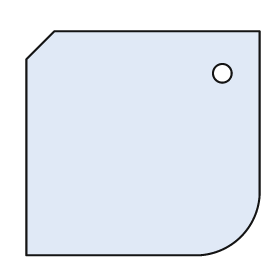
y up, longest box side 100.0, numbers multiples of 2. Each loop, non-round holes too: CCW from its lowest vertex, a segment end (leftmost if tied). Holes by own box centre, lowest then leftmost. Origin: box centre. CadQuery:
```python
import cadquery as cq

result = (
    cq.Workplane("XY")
    .moveTo(-50.0, -48.0)
    .lineTo(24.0, -48.0)
    .threePointArc((42.0, -40.0), (50.0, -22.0))
    .lineTo(50.0, 48.0)
    .lineTo(-38.0, 48.0)
    .lineTo(-50.0, 36.0)
    .close()
    .moveTo(34.0, 30.0)
    .circle(4.0)
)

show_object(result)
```